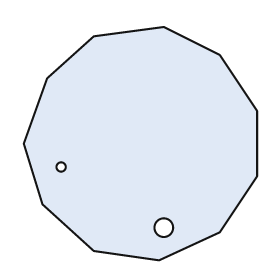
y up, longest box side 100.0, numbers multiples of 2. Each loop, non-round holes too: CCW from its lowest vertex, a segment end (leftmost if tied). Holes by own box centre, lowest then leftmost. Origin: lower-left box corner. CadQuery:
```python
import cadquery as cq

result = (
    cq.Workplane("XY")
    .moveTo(58.0, 0.0)
    .lineTo(84.0, 12.0)
    .lineTo(100.0, 36.0)
    .lineTo(100.0, 64.0)
    .lineTo(84.0, 88.0)
    .lineTo(60.0, 100.0)
    .lineTo(30.0, 96.0)
    .lineTo(10.0, 78.0)
    .lineTo(0.0, 50.0)
    .lineTo(8.0, 24.0)
    .lineTo(30.0, 4.0)
    .close()
    .moveTo(60.0, 14.0)
    .circle(4.0)
    .moveTo(16.0, 40.0)
    .circle(2.0)
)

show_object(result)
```